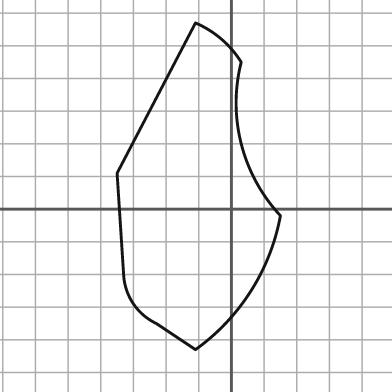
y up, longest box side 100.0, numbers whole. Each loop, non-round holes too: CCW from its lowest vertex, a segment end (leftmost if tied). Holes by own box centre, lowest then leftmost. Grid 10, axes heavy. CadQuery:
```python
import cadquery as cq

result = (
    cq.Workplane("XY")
    .moveTo(-11.0, -43.0)
    .threePointArc((6.0, -25.0), (15.0, -2.0))
    .threePointArc((3.0, 20.0), (3.0, 45.0))
    .threePointArc((-3.0, 52.0), (-11.0, 57.0))
    .lineTo(-35.0, 11.0)
    .lineTo(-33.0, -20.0)
    .threePointArc((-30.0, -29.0), (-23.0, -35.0))
    .close()
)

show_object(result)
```